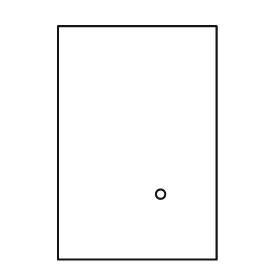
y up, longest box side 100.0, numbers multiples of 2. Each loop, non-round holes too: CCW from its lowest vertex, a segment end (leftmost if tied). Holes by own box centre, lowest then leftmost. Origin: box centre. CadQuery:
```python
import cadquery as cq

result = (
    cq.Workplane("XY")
    .moveTo(-34.0, -50.0)
    .lineTo(34.0, -50.0)
    .lineTo(34.0, 50.0)
    .lineTo(-34.0, 50.0)
    .close()
    .moveTo(10.0, -22.0)
    .circle(2.0)
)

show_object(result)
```